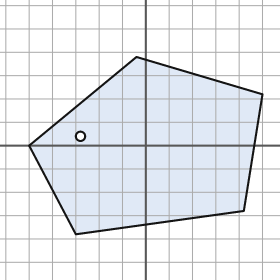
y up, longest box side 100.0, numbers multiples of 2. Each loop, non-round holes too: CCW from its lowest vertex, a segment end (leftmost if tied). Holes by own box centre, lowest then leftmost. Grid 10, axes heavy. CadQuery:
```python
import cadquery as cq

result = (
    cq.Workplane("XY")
    .moveTo(-30.0, -38.0)
    .lineTo(42.0, -28.0)
    .lineTo(50.0, 22.0)
    .lineTo(-4.0, 38.0)
    .lineTo(-50.0, 0.0)
    .close()
    .moveTo(-28.0, 4.0)
    .circle(2.0)
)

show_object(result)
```